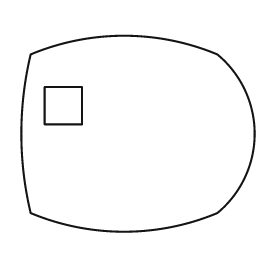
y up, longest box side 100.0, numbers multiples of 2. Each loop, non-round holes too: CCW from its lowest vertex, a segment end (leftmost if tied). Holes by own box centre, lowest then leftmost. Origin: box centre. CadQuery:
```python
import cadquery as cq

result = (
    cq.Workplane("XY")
    .moveTo(-46.0, -34.0)
    .threePointArc((-6.0, -42.0), (34.0, -34.0))
    .threePointArc((50.0, 0.0), (34.0, 34.0))
    .threePointArc((-6.0, 42.0), (-46.0, 34.0))
    .threePointArc((-50.0, 0.0), (-46.0, -34.0))
    .close()
    .moveTo(-40.0, 4.0)
    .lineTo(-24.0, 4.0)
    .lineTo(-24.0, 20.0)
    .lineTo(-40.0, 20.0)
    .close()
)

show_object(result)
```